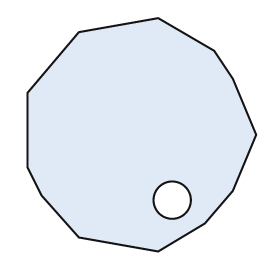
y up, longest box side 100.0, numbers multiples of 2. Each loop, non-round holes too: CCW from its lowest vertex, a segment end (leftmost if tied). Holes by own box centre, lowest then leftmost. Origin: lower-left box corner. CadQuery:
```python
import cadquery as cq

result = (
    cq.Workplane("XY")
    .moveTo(56.0, 0.0)
    .lineTo(76.0, 12.0)
    .lineTo(88.0, 26.0)
    .lineTo(98.0, 50.0)
    .lineTo(88.0, 74.0)
    .lineTo(80.0, 86.0)
    .lineTo(56.0, 100.0)
    .lineTo(22.0, 94.0)
    .lineTo(0.0, 68.0)
    .lineTo(0.0, 36.0)
    .lineTo(6.0, 24.0)
    .lineTo(22.0, 6.0)
    .close()
    .moveTo(62.0, 22.0)
    .circle(8.0)
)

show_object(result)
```